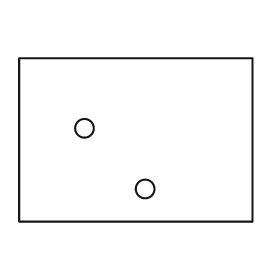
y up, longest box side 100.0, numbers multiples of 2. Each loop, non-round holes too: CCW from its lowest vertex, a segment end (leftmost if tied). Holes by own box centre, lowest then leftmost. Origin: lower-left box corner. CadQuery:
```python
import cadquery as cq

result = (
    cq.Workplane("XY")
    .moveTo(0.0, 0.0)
    .lineTo(100.0, 0.0)
    .lineTo(100.0, 70.0)
    .lineTo(0.0, 70.0)
    .close()
    .moveTo(54.0, 14.0)
    .circle(4.0)
    .moveTo(28.0, 40.0)
    .circle(4.0)
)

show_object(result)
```